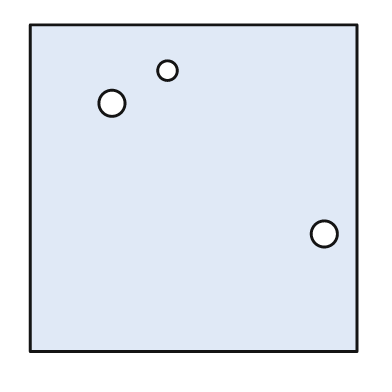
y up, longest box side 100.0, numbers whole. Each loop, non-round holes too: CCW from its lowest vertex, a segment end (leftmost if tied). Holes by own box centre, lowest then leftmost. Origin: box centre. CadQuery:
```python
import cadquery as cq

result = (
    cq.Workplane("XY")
    .moveTo(-50.0, -50.0)
    .lineTo(50.0, -50.0)
    .lineTo(50.0, 50.0)
    .lineTo(-50.0, 50.0)
    .close()
    .moveTo(40.0, -14.0)
    .circle(4.0)
    .moveTo(-25.0, 26.0)
    .circle(4.0)
    .moveTo(-8.0, 36.0)
    .circle(3.0)
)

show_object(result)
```